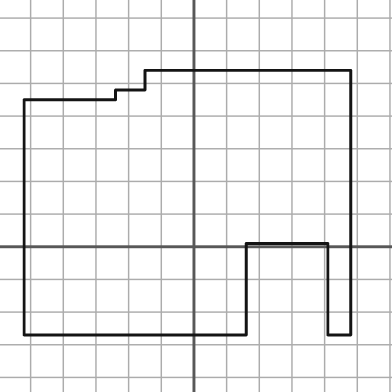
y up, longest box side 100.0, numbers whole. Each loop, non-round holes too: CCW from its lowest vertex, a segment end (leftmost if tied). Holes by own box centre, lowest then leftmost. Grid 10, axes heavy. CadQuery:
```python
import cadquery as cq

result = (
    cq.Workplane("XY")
    .moveTo(-52.0, -27.0)
    .lineTo(16.0, -27.0)
    .lineTo(16.0, 1.0)
    .lineTo(41.0, 1.0)
    .lineTo(41.0, -27.0)
    .lineTo(48.0, -27.0)
    .lineTo(48.0, 54.0)
    .lineTo(-15.0, 54.0)
    .lineTo(-15.0, 48.0)
    .lineTo(-24.0, 48.0)
    .lineTo(-24.0, 45.0)
    .lineTo(-52.0, 45.0)
    .close()
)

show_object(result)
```